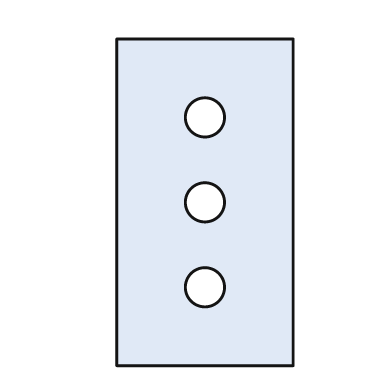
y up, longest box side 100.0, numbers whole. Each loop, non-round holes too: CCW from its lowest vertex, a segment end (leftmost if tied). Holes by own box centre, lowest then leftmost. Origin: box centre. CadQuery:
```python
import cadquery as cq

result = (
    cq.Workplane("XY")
    .moveTo(-27.0, -50.0)
    .lineTo(27.0, -50.0)
    .lineTo(27.0, 50.0)
    .lineTo(-27.0, 50.0)
    .close()
    .moveTo(0.0, -26.0)
    .circle(6.0)
    .moveTo(0.0, 0.0)
    .circle(6.0)
    .moveTo(0.0, 26.0)
    .circle(6.0)
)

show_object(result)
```